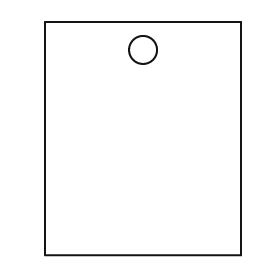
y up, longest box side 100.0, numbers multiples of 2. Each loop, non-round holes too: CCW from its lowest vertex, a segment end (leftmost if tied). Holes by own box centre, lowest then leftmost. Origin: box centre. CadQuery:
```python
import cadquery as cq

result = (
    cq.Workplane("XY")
    .moveTo(-42.0, -50.0)
    .lineTo(42.0, -50.0)
    .lineTo(42.0, 50.0)
    .lineTo(-42.0, 50.0)
    .close()
    .moveTo(0.0, 38.0)
    .circle(6.0)
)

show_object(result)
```